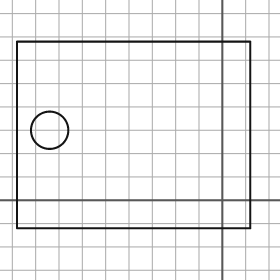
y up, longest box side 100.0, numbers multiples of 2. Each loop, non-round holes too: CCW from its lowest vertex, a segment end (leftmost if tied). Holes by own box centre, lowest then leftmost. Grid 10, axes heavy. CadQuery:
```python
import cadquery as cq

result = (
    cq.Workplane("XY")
    .moveTo(-88.0, -12.0)
    .lineTo(12.0, -12.0)
    .lineTo(12.0, 68.0)
    .lineTo(-88.0, 68.0)
    .close()
    .moveTo(-74.0, 30.0)
    .circle(8.0)
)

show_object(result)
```